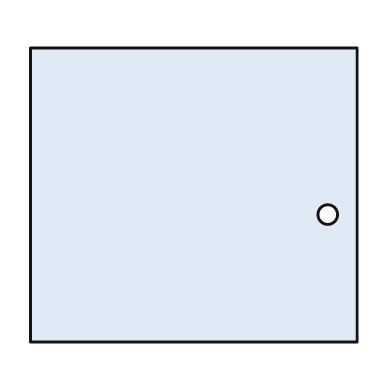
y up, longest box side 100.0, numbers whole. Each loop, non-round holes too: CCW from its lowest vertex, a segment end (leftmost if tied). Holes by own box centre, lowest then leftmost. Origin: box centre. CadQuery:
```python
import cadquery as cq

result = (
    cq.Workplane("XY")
    .moveTo(-50.0, -45.0)
    .lineTo(50.0, -45.0)
    .lineTo(50.0, 45.0)
    .lineTo(-50.0, 45.0)
    .close()
    .moveTo(41.0, -6.0)
    .circle(3.0)
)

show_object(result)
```